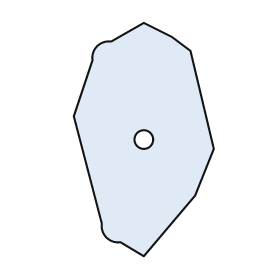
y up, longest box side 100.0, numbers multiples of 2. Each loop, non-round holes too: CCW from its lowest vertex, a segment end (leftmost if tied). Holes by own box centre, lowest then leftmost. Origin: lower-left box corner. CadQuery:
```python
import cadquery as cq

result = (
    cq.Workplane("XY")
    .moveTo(30.0, 0.0)
    .lineTo(52.0, 26.0)
    .lineTo(60.0, 46.0)
    .lineTo(50.0, 88.0)
    .lineTo(42.0, 94.0)
    .lineTo(30.0, 100.0)
    .lineTo(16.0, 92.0)
    .threePointArc((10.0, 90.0), (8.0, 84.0))
    .lineTo(0.0, 60.0)
    .lineTo(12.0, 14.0)
    .threePointArc((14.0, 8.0), (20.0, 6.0))
    .close()
    .moveTo(30.0, 50.0)
    .circle(4.0)
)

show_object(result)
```